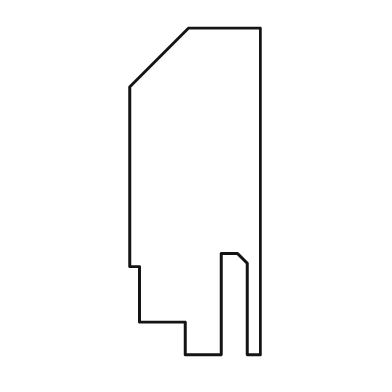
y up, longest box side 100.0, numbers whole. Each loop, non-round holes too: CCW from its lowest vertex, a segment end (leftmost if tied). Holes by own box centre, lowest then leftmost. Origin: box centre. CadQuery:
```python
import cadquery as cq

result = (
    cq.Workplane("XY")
    .moveTo(-3.0, -50.0)
    .lineTo(8.0, -50.0)
    .lineTo(8.0, -19.0)
    .lineTo(13.0, -19.0)
    .lineTo(16.0, -22.0)
    .lineTo(16.0, -50.0)
    .lineTo(20.0, -50.0)
    .lineTo(20.0, 50.0)
    .lineTo(-2.0, 50.0)
    .lineTo(-20.0, 32.0)
    .lineTo(-20.0, -23.0)
    .lineTo(-17.0, -23.0)
    .lineTo(-17.0, -40.0)
    .lineTo(-3.0, -40.0)
    .close()
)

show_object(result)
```